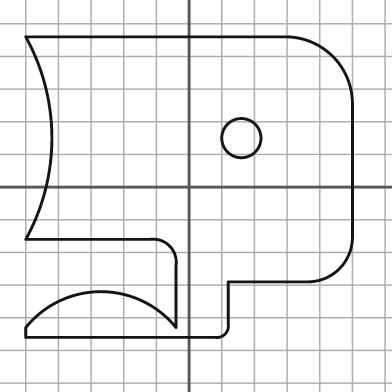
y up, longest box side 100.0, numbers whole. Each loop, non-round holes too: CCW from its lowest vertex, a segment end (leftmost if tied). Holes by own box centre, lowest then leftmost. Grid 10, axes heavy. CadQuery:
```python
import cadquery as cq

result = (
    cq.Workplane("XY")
    .moveTo(-50.0, -46.0)
    .lineTo(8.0, -46.0)
    .threePointArc((11.0, -45.0), (12.0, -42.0))
    .lineTo(12.0, -29.0)
    .lineTo(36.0, -29.0)
    .threePointArc((46.0, -25.0), (50.0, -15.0))
    .lineTo(50.0, 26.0)
    .threePointArc((44.0, 40.0), (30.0, 46.0))
    .lineTo(-50.0, 46.0)
    .threePointArc((-42.0, 15.0), (-50.0, -16.0))
    .lineTo(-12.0, -16.0)
    .threePointArc((-6.0, -18.0), (-4.0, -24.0))
    .lineTo(-4.0, -43.0)
    .threePointArc((-27.0, -32.0), (-50.0, -43.0))
    .close()
    .moveTo(16.0, 15.0)
    .circle(6.0)
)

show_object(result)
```